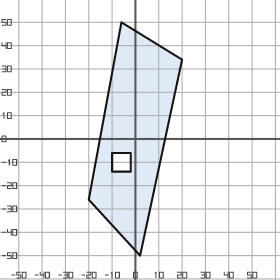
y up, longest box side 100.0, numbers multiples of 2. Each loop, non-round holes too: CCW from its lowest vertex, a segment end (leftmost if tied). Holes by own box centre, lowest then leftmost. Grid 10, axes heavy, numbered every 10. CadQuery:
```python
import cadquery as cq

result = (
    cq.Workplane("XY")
    .moveTo(2.0, -50.0)
    .lineTo(20.0, 34.0)
    .lineTo(-6.0, 50.0)
    .lineTo(-20.0, -26.0)
    .close()
    .moveTo(-10.0, -14.0)
    .lineTo(-2.0, -14.0)
    .lineTo(-2.0, -6.0)
    .lineTo(-10.0, -6.0)
    .close()
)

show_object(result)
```